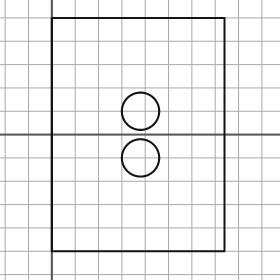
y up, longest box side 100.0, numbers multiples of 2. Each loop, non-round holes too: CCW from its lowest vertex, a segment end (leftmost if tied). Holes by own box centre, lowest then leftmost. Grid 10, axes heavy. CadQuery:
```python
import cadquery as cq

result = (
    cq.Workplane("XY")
    .moveTo(0.0, -50.0)
    .lineTo(74.0, -50.0)
    .lineTo(74.0, 50.0)
    .lineTo(0.0, 50.0)
    .close()
    .moveTo(38.0, -10.0)
    .circle(8.0)
    .moveTo(38.0, 10.0)
    .circle(8.0)
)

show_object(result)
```